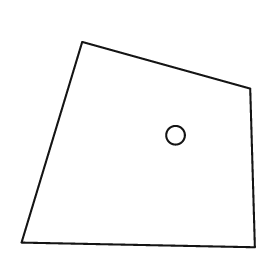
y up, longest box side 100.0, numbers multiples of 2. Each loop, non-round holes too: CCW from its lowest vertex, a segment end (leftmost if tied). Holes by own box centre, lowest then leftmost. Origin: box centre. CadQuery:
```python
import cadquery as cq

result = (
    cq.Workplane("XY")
    .moveTo(50.0, -44.0)
    .lineTo(48.0, 24.0)
    .lineTo(-24.0, 44.0)
    .lineTo(-50.0, -42.0)
    .close()
    .moveTo(16.0, 4.0)
    .circle(4.0)
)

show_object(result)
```